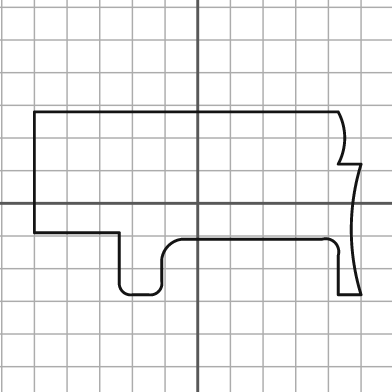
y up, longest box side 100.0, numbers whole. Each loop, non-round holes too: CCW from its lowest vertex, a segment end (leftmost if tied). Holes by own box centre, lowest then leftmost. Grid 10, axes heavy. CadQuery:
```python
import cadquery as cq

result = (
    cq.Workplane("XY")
    .moveTo(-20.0, -28.0)
    .lineTo(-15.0, -28.0)
    .threePointArc((-12.0, -27.0), (-11.0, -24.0))
    .lineTo(-11.0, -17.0)
    .threePointArc((-9.0, -13.0), (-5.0, -11.0))
    .lineTo(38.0, -11.0)
    .threePointArc((42.0, -12.0), (43.0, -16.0))
    .lineTo(43.0, -28.0)
    .lineTo(50.0, -28.0)
    .threePointArc((47.0, -8.0), (50.0, 12.0))
    .lineTo(43.0, 12.0)
    .threePointArc((45.0, 20.0), (43.0, 28.0))
    .lineTo(-50.0, 28.0)
    .lineTo(-50.0, -9.0)
    .lineTo(-24.0, -9.0)
    .lineTo(-24.0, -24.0)
    .threePointArc((-23.0, -27.0), (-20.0, -28.0))
    .close()
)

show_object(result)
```